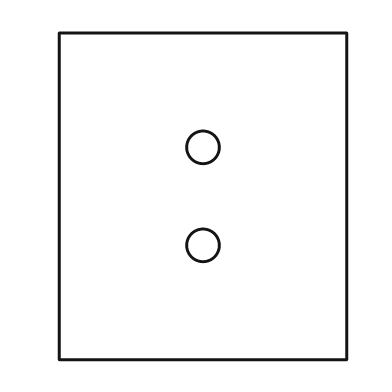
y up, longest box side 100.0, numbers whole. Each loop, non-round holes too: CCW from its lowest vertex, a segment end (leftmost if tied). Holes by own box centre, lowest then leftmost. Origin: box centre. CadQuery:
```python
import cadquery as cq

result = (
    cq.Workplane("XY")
    .moveTo(-44.0, -50.0)
    .lineTo(44.0, -50.0)
    .lineTo(44.0, 50.0)
    .lineTo(-44.0, 50.0)
    .close()
    .moveTo(0.0, -15.0)
    .circle(5.0)
    .moveTo(0.0, 15.0)
    .circle(5.0)
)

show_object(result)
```